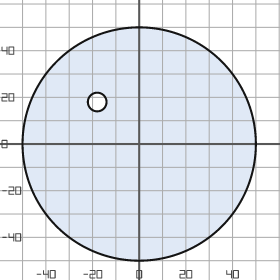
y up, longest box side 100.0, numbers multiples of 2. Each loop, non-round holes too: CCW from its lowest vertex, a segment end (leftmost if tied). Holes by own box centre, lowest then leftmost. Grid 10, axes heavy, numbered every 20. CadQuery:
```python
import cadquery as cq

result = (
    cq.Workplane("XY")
    .moveTo(0.0, 0.0)
    .circle(50.0)
    .moveTo(-18.0, 18.0)
    .circle(4.0)
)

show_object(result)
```